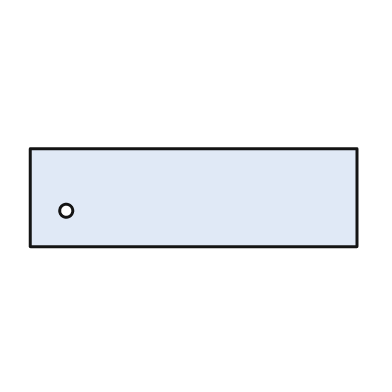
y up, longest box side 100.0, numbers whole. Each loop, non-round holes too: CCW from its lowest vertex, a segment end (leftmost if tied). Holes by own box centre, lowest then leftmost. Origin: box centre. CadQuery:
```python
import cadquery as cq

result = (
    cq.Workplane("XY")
    .moveTo(-50.0, -15.0)
    .lineTo(50.0, -15.0)
    .lineTo(50.0, 15.0)
    .lineTo(-50.0, 15.0)
    .close()
    .moveTo(-39.0, -4.0)
    .circle(2.0)
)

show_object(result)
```